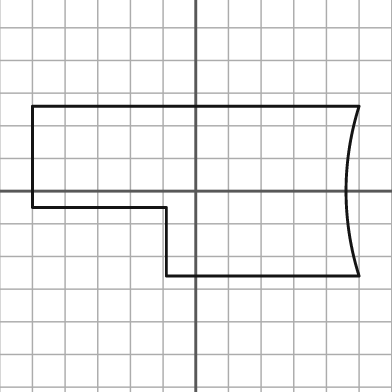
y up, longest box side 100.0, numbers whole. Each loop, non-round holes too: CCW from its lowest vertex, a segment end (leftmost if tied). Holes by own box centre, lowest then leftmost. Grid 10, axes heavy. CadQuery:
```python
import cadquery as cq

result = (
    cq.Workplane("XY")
    .moveTo(-9.0, -26.0)
    .lineTo(50.0, -26.0)
    .threePointArc((46.0, 0.0), (50.0, 26.0))
    .lineTo(-50.0, 26.0)
    .lineTo(-50.0, -5.0)
    .lineTo(-9.0, -5.0)
    .close()
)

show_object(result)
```